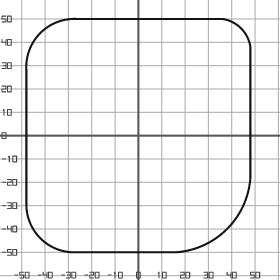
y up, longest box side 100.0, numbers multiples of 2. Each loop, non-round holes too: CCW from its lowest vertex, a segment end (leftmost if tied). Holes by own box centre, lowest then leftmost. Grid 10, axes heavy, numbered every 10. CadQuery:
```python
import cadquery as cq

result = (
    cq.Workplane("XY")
    .moveTo(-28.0, -50.0)
    .lineTo(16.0, -50.0)
    .threePointArc((38.0, -40.0), (48.0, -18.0))
    .lineTo(48.0, 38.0)
    .threePointArc((44.0, 46.0), (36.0, 50.0))
    .lineTo(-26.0, 50.0)
    .threePointArc((-42.0, 44.0), (-48.0, 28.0))
    .lineTo(-48.0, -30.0)
    .threePointArc((-42.0, -44.0), (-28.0, -50.0))
    .close()
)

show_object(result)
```